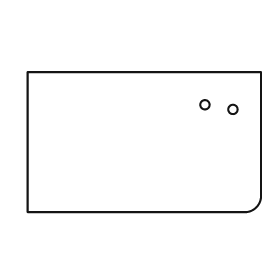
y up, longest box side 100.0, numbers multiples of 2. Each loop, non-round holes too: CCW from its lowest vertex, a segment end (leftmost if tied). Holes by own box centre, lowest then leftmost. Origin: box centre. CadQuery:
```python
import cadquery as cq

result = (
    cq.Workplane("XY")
    .moveTo(-50.0, -30.0)
    .lineTo(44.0, -30.0)
    .threePointArc((48.0, -28.0), (50.0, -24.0))
    .lineTo(50.0, 30.0)
    .lineTo(-50.0, 30.0)
    .close()
    .moveTo(38.0, 14.0)
    .circle(2.0)
    .moveTo(26.0, 16.0)
    .circle(2.0)
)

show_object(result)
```